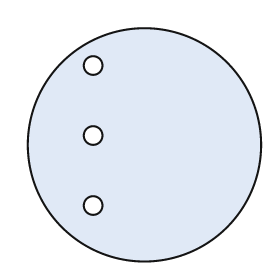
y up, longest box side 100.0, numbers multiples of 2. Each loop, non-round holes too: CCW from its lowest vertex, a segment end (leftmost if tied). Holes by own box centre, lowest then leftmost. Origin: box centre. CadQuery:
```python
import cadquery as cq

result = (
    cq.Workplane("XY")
    .moveTo(0.0, 0.0)
    .circle(50.0)
    .moveTo(-22.0, -26.0)
    .circle(4.0)
    .moveTo(-22.0, 4.0)
    .circle(4.0)
    .moveTo(-22.0, 34.0)
    .circle(4.0)
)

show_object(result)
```